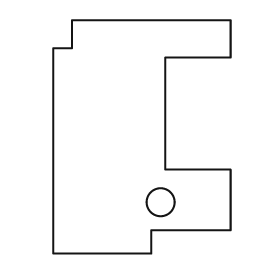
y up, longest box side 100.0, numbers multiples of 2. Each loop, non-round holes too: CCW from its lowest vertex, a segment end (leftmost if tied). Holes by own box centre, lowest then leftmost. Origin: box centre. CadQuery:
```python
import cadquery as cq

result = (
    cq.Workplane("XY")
    .moveTo(-38.0, -50.0)
    .lineTo(4.0, -50.0)
    .lineTo(4.0, -40.0)
    .lineTo(38.0, -40.0)
    .lineTo(38.0, -14.0)
    .lineTo(10.0, -14.0)
    .lineTo(10.0, 34.0)
    .lineTo(38.0, 34.0)
    .lineTo(38.0, 50.0)
    .lineTo(-30.0, 50.0)
    .lineTo(-30.0, 38.0)
    .lineTo(-38.0, 38.0)
    .close()
    .moveTo(8.0, -28.0)
    .circle(6.0)
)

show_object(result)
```